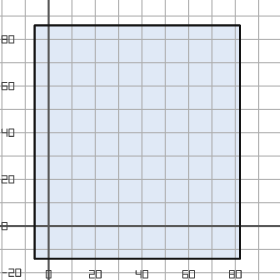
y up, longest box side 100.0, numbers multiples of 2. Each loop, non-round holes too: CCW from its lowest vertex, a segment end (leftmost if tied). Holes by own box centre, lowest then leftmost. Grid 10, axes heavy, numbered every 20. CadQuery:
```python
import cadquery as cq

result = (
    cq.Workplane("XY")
    .moveTo(-6.0, -14.0)
    .lineTo(82.0, -14.0)
    .lineTo(82.0, 86.0)
    .lineTo(-6.0, 86.0)
    .close()
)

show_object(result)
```